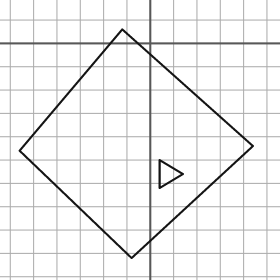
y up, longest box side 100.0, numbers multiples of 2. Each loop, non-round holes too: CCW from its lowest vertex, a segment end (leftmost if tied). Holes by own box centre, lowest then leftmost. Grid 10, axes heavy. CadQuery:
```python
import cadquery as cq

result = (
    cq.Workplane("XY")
    .moveTo(-8.0, -92.0)
    .lineTo(44.0, -44.0)
    .lineTo(-12.0, 6.0)
    .lineTo(-56.0, -46.0)
    .close()
    .moveTo(4.0, -62.0)
    .lineTo(14.0, -56.0)
    .lineTo(4.0, -50.0)
    .close()
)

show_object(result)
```